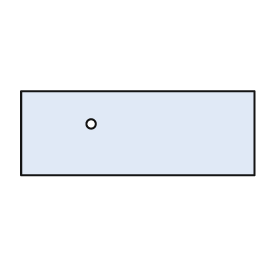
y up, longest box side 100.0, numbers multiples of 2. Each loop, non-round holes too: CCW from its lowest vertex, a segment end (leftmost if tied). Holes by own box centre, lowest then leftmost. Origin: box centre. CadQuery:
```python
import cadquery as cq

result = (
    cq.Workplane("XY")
    .moveTo(-50.0, -18.0)
    .lineTo(50.0, -18.0)
    .lineTo(50.0, 18.0)
    .lineTo(-50.0, 18.0)
    .close()
    .moveTo(-20.0, 4.0)
    .circle(2.0)
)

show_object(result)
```